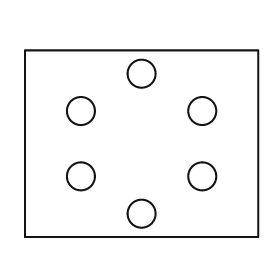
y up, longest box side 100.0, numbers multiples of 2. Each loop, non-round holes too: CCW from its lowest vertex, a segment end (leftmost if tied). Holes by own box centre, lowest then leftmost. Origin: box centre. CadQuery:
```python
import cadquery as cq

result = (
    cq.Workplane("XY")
    .moveTo(-50.0, -40.0)
    .lineTo(50.0, -40.0)
    .lineTo(50.0, 40.0)
    .lineTo(-50.0, 40.0)
    .close()
    .moveTo(0.0, -30.0)
    .circle(6.0)
    .moveTo(-26.0, -14.0)
    .circle(6.0)
    .moveTo(26.0, -14.0)
    .circle(6.0)
    .moveTo(-26.0, 14.0)
    .circle(6.0)
    .moveTo(26.0, 14.0)
    .circle(6.0)
    .moveTo(0.0, 30.0)
    .circle(6.0)
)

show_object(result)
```